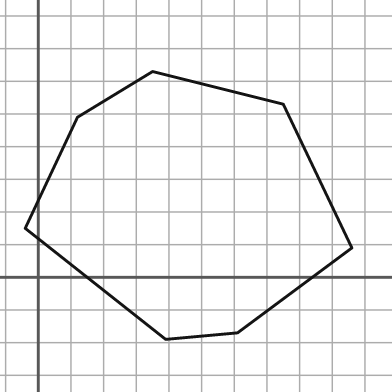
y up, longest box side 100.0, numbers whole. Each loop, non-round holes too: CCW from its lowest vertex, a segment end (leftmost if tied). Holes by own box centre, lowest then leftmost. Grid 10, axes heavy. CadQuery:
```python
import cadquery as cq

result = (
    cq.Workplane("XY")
    .moveTo(39.0, -19.0)
    .lineTo(61.0, -17.0)
    .lineTo(96.0, 9.0)
    .lineTo(75.0, 53.0)
    .lineTo(35.0, 63.0)
    .lineTo(12.0, 49.0)
    .lineTo(-4.0, 15.0)
    .close()
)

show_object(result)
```